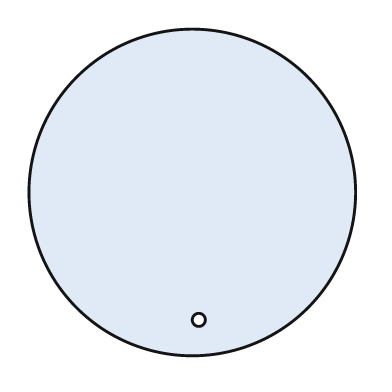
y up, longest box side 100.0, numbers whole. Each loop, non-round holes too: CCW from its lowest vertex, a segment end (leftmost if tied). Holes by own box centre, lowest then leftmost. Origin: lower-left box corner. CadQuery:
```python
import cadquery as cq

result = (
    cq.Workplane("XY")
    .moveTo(50.0, 50.0)
    .circle(50.0)
    .moveTo(52.0, 11.0)
    .circle(2.0)
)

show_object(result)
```